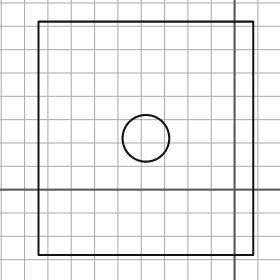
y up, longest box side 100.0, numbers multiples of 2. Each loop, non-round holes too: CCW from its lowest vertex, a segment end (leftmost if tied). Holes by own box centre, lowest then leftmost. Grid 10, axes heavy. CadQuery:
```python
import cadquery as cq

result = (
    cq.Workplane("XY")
    .moveTo(-84.0, -28.0)
    .lineTo(8.0, -28.0)
    .lineTo(8.0, 72.0)
    .lineTo(-84.0, 72.0)
    .close()
    .moveTo(-38.0, 22.0)
    .circle(10.0)
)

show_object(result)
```